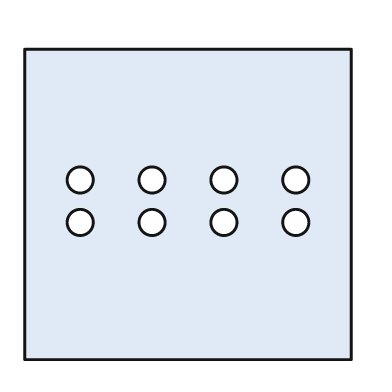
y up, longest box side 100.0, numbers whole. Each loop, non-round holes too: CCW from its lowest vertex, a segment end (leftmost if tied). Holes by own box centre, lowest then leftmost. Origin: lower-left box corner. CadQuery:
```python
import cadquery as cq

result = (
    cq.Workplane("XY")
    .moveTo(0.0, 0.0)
    .lineTo(100.0, 0.0)
    .lineTo(100.0, 95.0)
    .lineTo(0.0, 95.0)
    .close()
    .moveTo(17.0, 42.0)
    .circle(4.0)
    .moveTo(39.0, 42.0)
    .circle(4.0)
    .moveTo(61.0, 42.0)
    .circle(4.0)
    .moveTo(83.0, 42.0)
    .circle(4.0)
    .moveTo(17.0, 55.0)
    .circle(4.0)
    .moveTo(39.0, 55.0)
    .circle(4.0)
    .moveTo(61.0, 55.0)
    .circle(4.0)
    .moveTo(83.0, 55.0)
    .circle(4.0)
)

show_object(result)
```